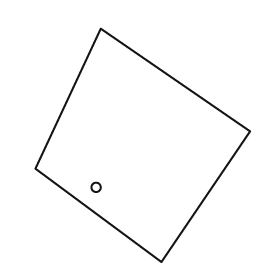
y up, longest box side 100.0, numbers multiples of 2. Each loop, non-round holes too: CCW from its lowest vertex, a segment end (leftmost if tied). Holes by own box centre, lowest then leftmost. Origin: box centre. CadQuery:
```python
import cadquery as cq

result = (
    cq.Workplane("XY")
    .moveTo(8.0, -50.0)
    .lineTo(46.0, 6.0)
    .lineTo(-18.0, 50.0)
    .lineTo(-46.0, -10.0)
    .close()
    .moveTo(-20.0, -18.0)
    .circle(2.0)
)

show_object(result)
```